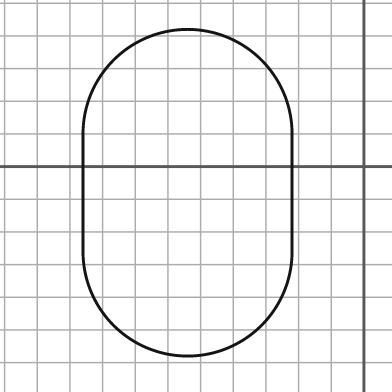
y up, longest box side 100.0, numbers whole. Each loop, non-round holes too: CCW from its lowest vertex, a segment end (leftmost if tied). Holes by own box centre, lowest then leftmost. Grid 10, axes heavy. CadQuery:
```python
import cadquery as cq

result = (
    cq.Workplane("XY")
    .moveTo(-86.0, -26.0)
    .threePointArc((-54.0, -58.0), (-22.0, -26.0))
    .lineTo(-22.0, 10.0)
    .threePointArc((-54.0, 42.0), (-86.0, 10.0))
    .close()
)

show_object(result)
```